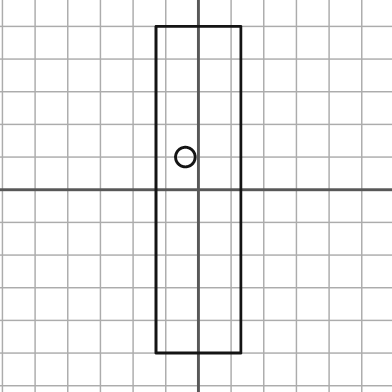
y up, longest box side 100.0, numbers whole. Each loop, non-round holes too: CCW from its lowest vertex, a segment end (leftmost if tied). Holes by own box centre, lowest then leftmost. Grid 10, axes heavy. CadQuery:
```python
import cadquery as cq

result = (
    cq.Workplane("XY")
    .moveTo(-13.0, -50.0)
    .lineTo(13.0, -50.0)
    .lineTo(13.0, 50.0)
    .lineTo(-13.0, 50.0)
    .close()
    .moveTo(-4.0, 10.0)
    .circle(3.0)
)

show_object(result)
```